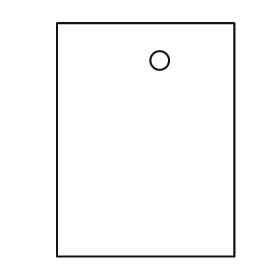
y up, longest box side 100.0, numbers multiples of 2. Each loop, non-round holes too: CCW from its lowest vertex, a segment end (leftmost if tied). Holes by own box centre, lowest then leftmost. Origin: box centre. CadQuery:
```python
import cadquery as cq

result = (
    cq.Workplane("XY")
    .moveTo(-38.0, -50.0)
    .lineTo(38.0, -50.0)
    .lineTo(38.0, 50.0)
    .lineTo(-38.0, 50.0)
    .close()
    .moveTo(6.0, 34.0)
    .circle(4.0)
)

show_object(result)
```